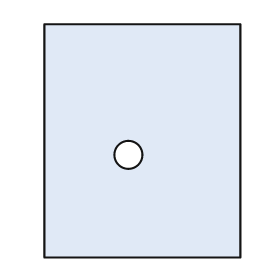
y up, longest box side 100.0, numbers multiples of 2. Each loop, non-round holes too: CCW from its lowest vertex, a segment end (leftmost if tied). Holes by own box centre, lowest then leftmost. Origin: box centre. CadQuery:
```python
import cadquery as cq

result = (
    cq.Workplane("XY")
    .moveTo(-42.0, -50.0)
    .lineTo(42.0, -50.0)
    .lineTo(42.0, 50.0)
    .lineTo(-42.0, 50.0)
    .close()
    .moveTo(-6.0, -6.0)
    .circle(6.0)
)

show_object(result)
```